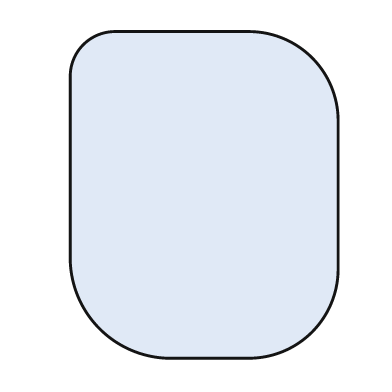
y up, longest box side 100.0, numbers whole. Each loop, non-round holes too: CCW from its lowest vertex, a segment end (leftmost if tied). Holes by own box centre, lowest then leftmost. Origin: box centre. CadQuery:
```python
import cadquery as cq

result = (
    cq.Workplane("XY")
    .moveTo(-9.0, -50.0)
    .lineTo(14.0, -50.0)
    .threePointArc((33.0, -42.0), (41.0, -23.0))
    .lineTo(41.0, 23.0)
    .threePointArc((33.0, 42.0), (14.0, 50.0))
    .lineTo(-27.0, 50.0)
    .threePointArc((-37.0, 46.0), (-41.0, 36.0))
    .lineTo(-41.0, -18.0)
    .threePointArc((-32.0, -41.0), (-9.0, -50.0))
    .close()
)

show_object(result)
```